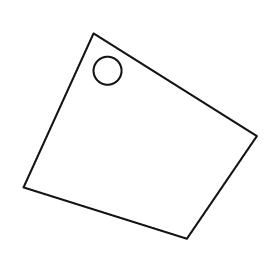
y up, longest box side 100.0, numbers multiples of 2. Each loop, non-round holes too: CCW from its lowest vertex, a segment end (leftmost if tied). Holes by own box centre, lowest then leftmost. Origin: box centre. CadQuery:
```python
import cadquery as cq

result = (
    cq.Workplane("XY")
    .moveTo(20.0, -44.0)
    .lineTo(50.0, 0.0)
    .lineTo(-20.0, 44.0)
    .lineTo(-50.0, -22.0)
    .close()
    .moveTo(-14.0, 28.0)
    .circle(6.0)
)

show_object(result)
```